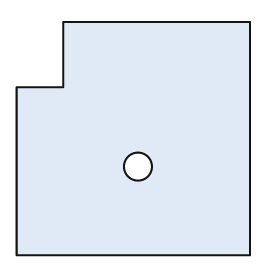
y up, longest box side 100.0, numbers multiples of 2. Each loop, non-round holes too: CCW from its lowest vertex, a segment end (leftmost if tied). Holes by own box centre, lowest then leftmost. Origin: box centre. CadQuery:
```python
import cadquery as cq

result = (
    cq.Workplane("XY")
    .moveTo(-50.0, -50.0)
    .lineTo(50.0, -50.0)
    .lineTo(50.0, 50.0)
    .lineTo(-30.0, 50.0)
    .lineTo(-30.0, 22.0)
    .lineTo(-50.0, 22.0)
    .close()
    .moveTo(2.0, -12.0)
    .circle(6.0)
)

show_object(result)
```